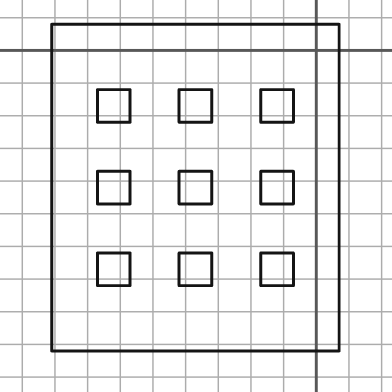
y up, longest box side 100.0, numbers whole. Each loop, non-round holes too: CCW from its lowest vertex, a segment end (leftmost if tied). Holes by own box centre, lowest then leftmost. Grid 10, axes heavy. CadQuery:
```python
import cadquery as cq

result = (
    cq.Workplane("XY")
    .moveTo(-81.0, -92.0)
    .lineTo(7.0, -92.0)
    .lineTo(7.0, 8.0)
    .lineTo(-81.0, 8.0)
    .close()
    .moveTo(-67.0, -72.0)
    .lineTo(-57.0, -72.0)
    .lineTo(-57.0, -62.0)
    .lineTo(-67.0, -62.0)
    .close()
    .moveTo(-42.0, -72.0)
    .lineTo(-32.0, -72.0)
    .lineTo(-32.0, -62.0)
    .lineTo(-42.0, -62.0)
    .close()
    .moveTo(-17.0, -72.0)
    .lineTo(-7.0, -72.0)
    .lineTo(-7.0, -62.0)
    .lineTo(-17.0, -62.0)
    .close()
    .moveTo(-67.0, -47.0)
    .lineTo(-57.0, -47.0)
    .lineTo(-57.0, -37.0)
    .lineTo(-67.0, -37.0)
    .close()
    .moveTo(-42.0, -47.0)
    .lineTo(-32.0, -47.0)
    .lineTo(-32.0, -37.0)
    .lineTo(-42.0, -37.0)
    .close()
    .moveTo(-17.0, -47.0)
    .lineTo(-7.0, -47.0)
    .lineTo(-7.0, -37.0)
    .lineTo(-17.0, -37.0)
    .close()
    .moveTo(-67.0, -22.0)
    .lineTo(-57.0, -22.0)
    .lineTo(-57.0, -12.0)
    .lineTo(-67.0, -12.0)
    .close()
    .moveTo(-42.0, -22.0)
    .lineTo(-32.0, -22.0)
    .lineTo(-32.0, -12.0)
    .lineTo(-42.0, -12.0)
    .close()
    .moveTo(-17.0, -22.0)
    .lineTo(-7.0, -22.0)
    .lineTo(-7.0, -12.0)
    .lineTo(-17.0, -12.0)
    .close()
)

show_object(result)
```